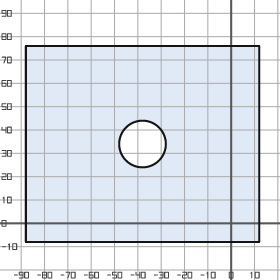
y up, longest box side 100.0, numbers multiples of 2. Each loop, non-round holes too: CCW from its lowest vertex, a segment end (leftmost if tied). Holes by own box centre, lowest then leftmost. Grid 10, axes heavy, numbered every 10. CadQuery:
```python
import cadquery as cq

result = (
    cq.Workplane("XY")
    .moveTo(-88.0, -8.0)
    .lineTo(12.0, -8.0)
    .lineTo(12.0, 76.0)
    .lineTo(-88.0, 76.0)
    .close()
    .moveTo(-38.0, 34.0)
    .circle(10.0)
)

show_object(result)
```